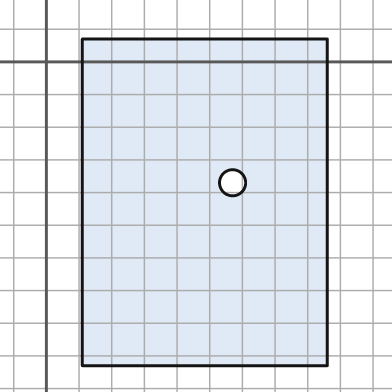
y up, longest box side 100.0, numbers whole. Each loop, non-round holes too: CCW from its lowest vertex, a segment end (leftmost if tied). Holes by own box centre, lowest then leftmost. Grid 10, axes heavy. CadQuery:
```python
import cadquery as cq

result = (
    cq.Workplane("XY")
    .moveTo(11.0, -93.0)
    .lineTo(86.0, -93.0)
    .lineTo(86.0, 7.0)
    .lineTo(11.0, 7.0)
    .close()
    .moveTo(57.0, -37.0)
    .circle(4.0)
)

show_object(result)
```